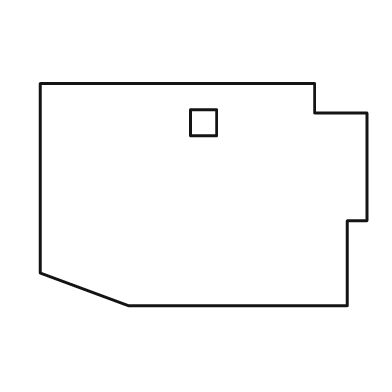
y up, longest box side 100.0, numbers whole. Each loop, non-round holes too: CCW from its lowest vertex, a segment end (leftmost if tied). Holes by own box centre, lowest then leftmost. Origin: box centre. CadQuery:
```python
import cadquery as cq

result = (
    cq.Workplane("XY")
    .moveTo(-23.0, -34.0)
    .lineTo(44.0, -34.0)
    .lineTo(44.0, -8.0)
    .lineTo(50.0, -8.0)
    .lineTo(50.0, 25.0)
    .lineTo(34.0, 25.0)
    .lineTo(34.0, 34.0)
    .lineTo(-50.0, 34.0)
    .lineTo(-50.0, -24.0)
    .close()
    .moveTo(-4.0, 18.0)
    .lineTo(4.0, 18.0)
    .lineTo(4.0, 26.0)
    .lineTo(-4.0, 26.0)
    .close()
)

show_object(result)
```